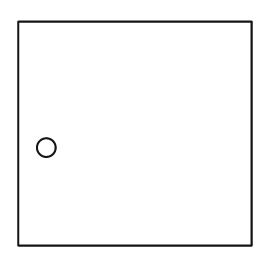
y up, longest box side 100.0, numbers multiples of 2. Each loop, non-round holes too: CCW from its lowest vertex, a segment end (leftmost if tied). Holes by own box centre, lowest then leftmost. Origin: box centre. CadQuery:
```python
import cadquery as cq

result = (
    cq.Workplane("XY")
    .moveTo(-50.0, -48.0)
    .lineTo(50.0, -48.0)
    .lineTo(50.0, 48.0)
    .lineTo(-50.0, 48.0)
    .close()
    .moveTo(-38.0, -6.0)
    .circle(4.0)
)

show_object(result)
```